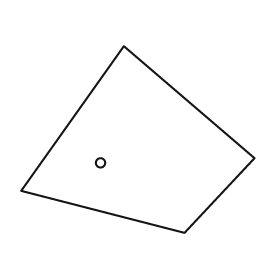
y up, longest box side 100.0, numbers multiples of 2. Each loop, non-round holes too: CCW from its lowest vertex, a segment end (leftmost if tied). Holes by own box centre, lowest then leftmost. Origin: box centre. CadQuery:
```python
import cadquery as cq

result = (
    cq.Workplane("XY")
    .moveTo(20.0, -40.0)
    .lineTo(50.0, -8.0)
    .lineTo(-6.0, 40.0)
    .lineTo(-50.0, -22.0)
    .close()
    .moveTo(-16.0, -10.0)
    .circle(2.0)
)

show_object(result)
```